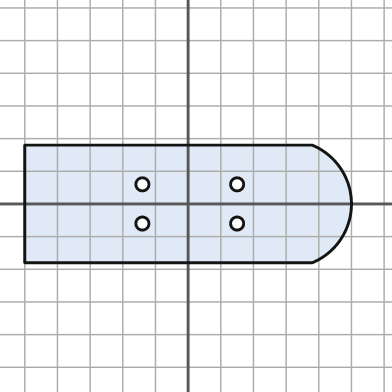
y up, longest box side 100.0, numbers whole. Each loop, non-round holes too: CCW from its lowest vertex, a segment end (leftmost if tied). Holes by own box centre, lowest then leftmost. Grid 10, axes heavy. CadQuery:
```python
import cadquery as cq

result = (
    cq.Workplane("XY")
    .moveTo(-50.0, -18.0)
    .lineTo(38.0, -18.0)
    .threePointArc((50.0, 0.0), (38.0, 18.0))
    .lineTo(-50.0, 18.0)
    .close()
    .moveTo(-14.0, -6.0)
    .circle(2.0)
    .moveTo(15.0, -6.0)
    .circle(2.0)
    .moveTo(-14.0, 6.0)
    .circle(2.0)
    .moveTo(15.0, 6.0)
    .circle(2.0)
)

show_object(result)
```